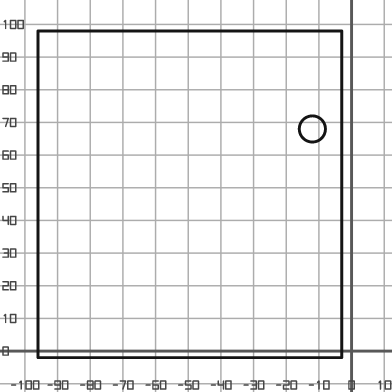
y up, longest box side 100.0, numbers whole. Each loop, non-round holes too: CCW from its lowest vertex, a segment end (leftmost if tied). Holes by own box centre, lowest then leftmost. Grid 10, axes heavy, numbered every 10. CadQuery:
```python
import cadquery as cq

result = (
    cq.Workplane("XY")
    .moveTo(-96.0, -2.0)
    .lineTo(-3.0, -2.0)
    .lineTo(-3.0, 98.0)
    .lineTo(-96.0, 98.0)
    .close()
    .moveTo(-12.0, 68.0)
    .circle(4.0)
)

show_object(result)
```